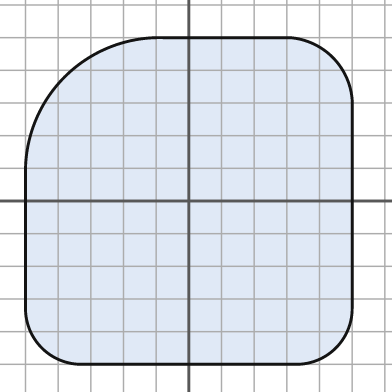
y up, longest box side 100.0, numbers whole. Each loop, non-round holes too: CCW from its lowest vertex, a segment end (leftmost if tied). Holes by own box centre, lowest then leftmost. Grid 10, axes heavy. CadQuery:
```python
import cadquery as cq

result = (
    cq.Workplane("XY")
    .moveTo(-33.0, -50.0)
    .lineTo(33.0, -50.0)
    .threePointArc((45.0, -45.0), (50.0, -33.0))
    .lineTo(50.0, 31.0)
    .threePointArc((44.0, 44.0), (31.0, 50.0))
    .lineTo(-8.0, 50.0)
    .threePointArc((-38.0, 38.0), (-50.0, 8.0))
    .lineTo(-50.0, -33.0)
    .threePointArc((-45.0, -45.0), (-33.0, -50.0))
    .close()
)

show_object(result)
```